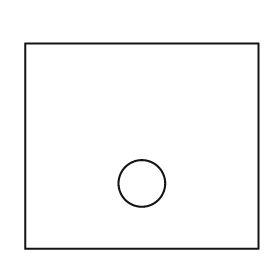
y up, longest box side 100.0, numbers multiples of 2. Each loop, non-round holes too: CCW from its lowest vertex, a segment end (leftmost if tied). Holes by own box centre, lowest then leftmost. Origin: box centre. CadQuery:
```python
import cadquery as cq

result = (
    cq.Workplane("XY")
    .moveTo(-50.0, -44.0)
    .lineTo(50.0, -44.0)
    .lineTo(50.0, 44.0)
    .lineTo(-50.0, 44.0)
    .close()
    .moveTo(0.0, -16.0)
    .circle(10.0)
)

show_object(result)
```